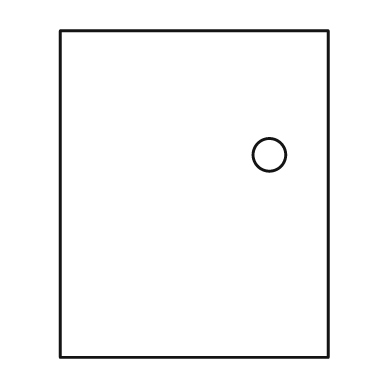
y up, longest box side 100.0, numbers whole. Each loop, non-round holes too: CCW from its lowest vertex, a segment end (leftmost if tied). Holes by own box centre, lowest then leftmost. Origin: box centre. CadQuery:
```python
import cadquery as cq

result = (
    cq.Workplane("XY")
    .moveTo(-41.0, -50.0)
    .lineTo(41.0, -50.0)
    .lineTo(41.0, 50.0)
    .lineTo(-41.0, 50.0)
    .close()
    .moveTo(23.0, 12.0)
    .circle(5.0)
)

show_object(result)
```